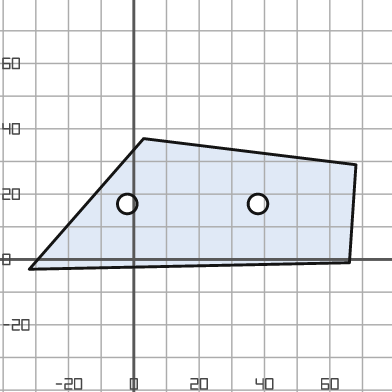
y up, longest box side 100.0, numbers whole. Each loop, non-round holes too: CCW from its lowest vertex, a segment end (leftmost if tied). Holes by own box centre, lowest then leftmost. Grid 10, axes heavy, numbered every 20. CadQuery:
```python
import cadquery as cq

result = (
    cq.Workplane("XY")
    .moveTo(-32.0, -3.0)
    .lineTo(66.0, -1.0)
    .lineTo(68.0, 29.0)
    .lineTo(3.0, 37.0)
    .close()
    .moveTo(-2.0, 17.0)
    .circle(3.0)
    .moveTo(38.0, 17.0)
    .circle(3.0)
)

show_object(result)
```